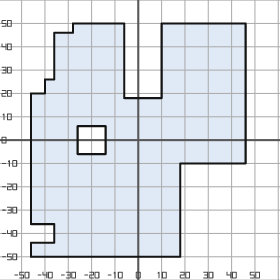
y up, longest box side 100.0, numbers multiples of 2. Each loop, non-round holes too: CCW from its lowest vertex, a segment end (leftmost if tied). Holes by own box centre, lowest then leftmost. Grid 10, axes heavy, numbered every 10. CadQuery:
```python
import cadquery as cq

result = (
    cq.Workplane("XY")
    .moveTo(-46.0, -50.0)
    .lineTo(18.0, -50.0)
    .lineTo(18.0, -10.0)
    .lineTo(46.0, -10.0)
    .lineTo(46.0, 50.0)
    .lineTo(10.0, 50.0)
    .lineTo(10.0, 18.0)
    .lineTo(-6.0, 18.0)
    .lineTo(-6.0, 50.0)
    .lineTo(-28.0, 50.0)
    .lineTo(-28.0, 46.0)
    .lineTo(-36.0, 46.0)
    .lineTo(-36.0, 26.0)
    .lineTo(-40.0, 26.0)
    .lineTo(-40.0, 20.0)
    .lineTo(-46.0, 20.0)
    .lineTo(-46.0, -36.0)
    .lineTo(-36.0, -36.0)
    .lineTo(-36.0, -44.0)
    .lineTo(-46.0, -44.0)
    .close()
    .moveTo(-26.0, -6.0)
    .lineTo(-14.0, -6.0)
    .lineTo(-14.0, 6.0)
    .lineTo(-26.0, 6.0)
    .close()
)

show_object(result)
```